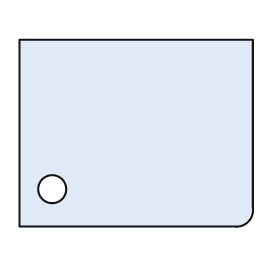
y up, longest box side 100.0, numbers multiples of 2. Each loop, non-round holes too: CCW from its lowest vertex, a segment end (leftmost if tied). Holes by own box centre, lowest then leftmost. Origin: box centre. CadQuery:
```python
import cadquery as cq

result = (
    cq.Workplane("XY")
    .moveTo(-50.0, -40.0)
    .lineTo(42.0, -40.0)
    .threePointArc((48.0, -38.0), (50.0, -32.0))
    .lineTo(50.0, 40.0)
    .lineTo(-50.0, 40.0)
    .close()
    .moveTo(-36.0, -24.0)
    .circle(6.0)
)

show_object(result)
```